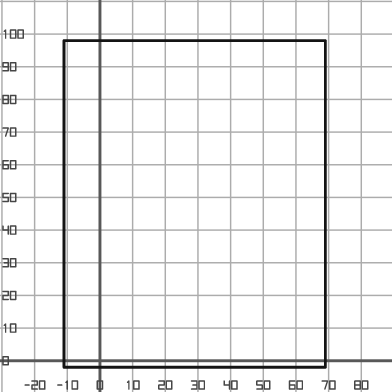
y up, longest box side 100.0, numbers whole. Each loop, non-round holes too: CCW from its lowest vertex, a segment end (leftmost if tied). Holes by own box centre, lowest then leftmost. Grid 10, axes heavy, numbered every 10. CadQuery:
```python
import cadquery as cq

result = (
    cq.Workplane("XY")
    .moveTo(-11.0, -2.0)
    .lineTo(69.0, -2.0)
    .lineTo(69.0, 98.0)
    .lineTo(-11.0, 98.0)
    .close()
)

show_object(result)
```